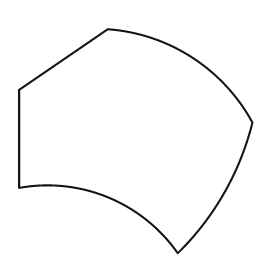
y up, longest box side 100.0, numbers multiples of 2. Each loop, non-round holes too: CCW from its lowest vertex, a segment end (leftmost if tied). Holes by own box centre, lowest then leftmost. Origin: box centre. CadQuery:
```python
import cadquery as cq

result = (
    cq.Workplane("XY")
    .moveTo(18.0, -48.0)
    .threePointArc((38.0, -22.0), (50.0, 8.0))
    .threePointArc((24.0, 36.0), (-12.0, 48.0))
    .lineTo(-50.0, 22.0)
    .lineTo(-50.0, -20.0)
    .threePointArc((-12.0, -24.0), (18.0, -48.0))
    .close()
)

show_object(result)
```